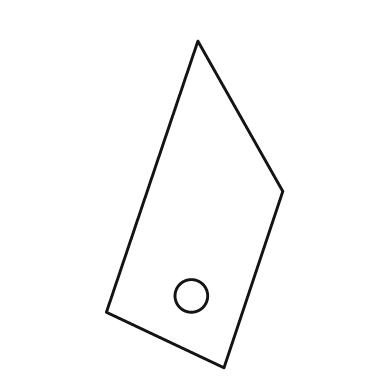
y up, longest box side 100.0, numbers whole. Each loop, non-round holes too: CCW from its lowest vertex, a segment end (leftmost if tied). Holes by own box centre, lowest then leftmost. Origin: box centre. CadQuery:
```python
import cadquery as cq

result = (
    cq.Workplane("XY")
    .moveTo(9.0, -50.0)
    .lineTo(27.0, 4.0)
    .lineTo(1.0, 50.0)
    .lineTo(-27.0, -33.0)
    .close()
    .moveTo(-1.0, -28.0)
    .circle(5.0)
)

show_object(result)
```